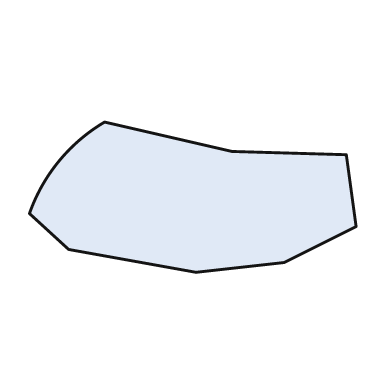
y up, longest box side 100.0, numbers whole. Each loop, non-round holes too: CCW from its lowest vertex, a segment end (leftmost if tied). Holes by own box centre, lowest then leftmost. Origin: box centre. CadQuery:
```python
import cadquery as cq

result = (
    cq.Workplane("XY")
    .moveTo(1.0, -23.0)
    .lineTo(28.0, -20.0)
    .lineTo(50.0, -9.0)
    .lineTo(47.0, 13.0)
    .lineTo(12.0, 14.0)
    .lineTo(-27.0, 23.0)
    .threePointArc((-41.0, 11.0), (-50.0, -5.0))
    .lineTo(-38.0, -16.0)
    .close()
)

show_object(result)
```